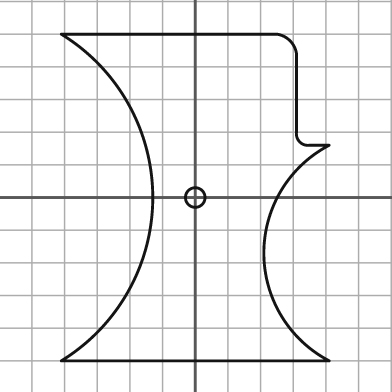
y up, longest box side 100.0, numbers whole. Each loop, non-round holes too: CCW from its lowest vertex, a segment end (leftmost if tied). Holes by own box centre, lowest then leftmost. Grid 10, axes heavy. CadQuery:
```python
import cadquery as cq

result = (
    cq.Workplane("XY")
    .moveTo(-41.0, -50.0)
    .lineTo(41.0, -50.0)
    .threePointArc((21.0, -17.0), (41.0, 16.0))
    .lineTo(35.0, 16.0)
    .threePointArc((32.0, 17.0), (31.0, 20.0))
    .lineTo(31.0, 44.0)
    .threePointArc((29.0, 48.0), (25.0, 50.0))
    .lineTo(-41.0, 50.0)
    .threePointArc((-13.0, 0.0), (-41.0, -50.0))
    .close()
    .moveTo(0.0, 0.0)
    .circle(3.0)
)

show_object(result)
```